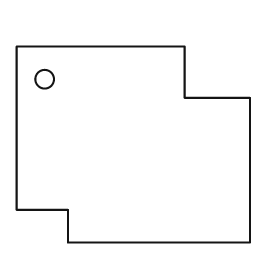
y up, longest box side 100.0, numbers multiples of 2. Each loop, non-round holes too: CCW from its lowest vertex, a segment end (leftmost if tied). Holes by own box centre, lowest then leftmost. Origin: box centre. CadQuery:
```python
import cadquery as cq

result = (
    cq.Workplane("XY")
    .moveTo(-28.0, -42.0)
    .lineTo(50.0, -42.0)
    .lineTo(50.0, 20.0)
    .lineTo(22.0, 20.0)
    .lineTo(22.0, 42.0)
    .lineTo(-50.0, 42.0)
    .lineTo(-50.0, -28.0)
    .lineTo(-28.0, -28.0)
    .close()
    .moveTo(-38.0, 28.0)
    .circle(4.0)
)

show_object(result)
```